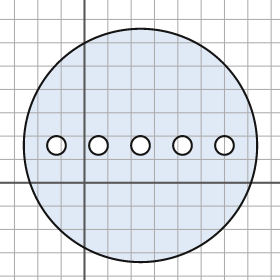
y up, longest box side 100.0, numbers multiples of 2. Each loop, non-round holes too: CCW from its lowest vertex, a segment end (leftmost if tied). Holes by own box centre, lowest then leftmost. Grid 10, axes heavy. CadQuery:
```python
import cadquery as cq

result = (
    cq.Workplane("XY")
    .moveTo(24.0, 16.0)
    .circle(50.0)
    .moveTo(-12.0, 16.0)
    .circle(4.0)
    .moveTo(6.0, 16.0)
    .circle(4.0)
    .moveTo(24.0, 16.0)
    .circle(4.0)
    .moveTo(42.0, 16.0)
    .circle(4.0)
    .moveTo(60.0, 16.0)
    .circle(4.0)
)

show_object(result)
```